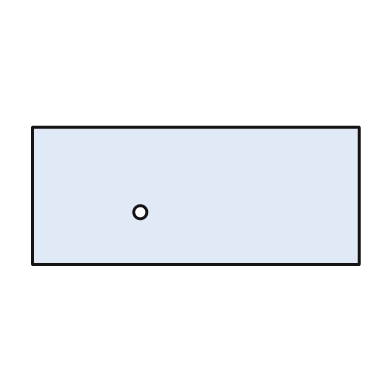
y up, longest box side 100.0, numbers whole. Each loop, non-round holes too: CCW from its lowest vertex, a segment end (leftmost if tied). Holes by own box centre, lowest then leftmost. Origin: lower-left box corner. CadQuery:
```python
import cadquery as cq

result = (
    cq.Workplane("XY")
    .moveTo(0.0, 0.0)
    .lineTo(100.0, 0.0)
    .lineTo(100.0, 42.0)
    .lineTo(0.0, 42.0)
    .close()
    .moveTo(33.0, 16.0)
    .circle(2.0)
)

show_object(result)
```